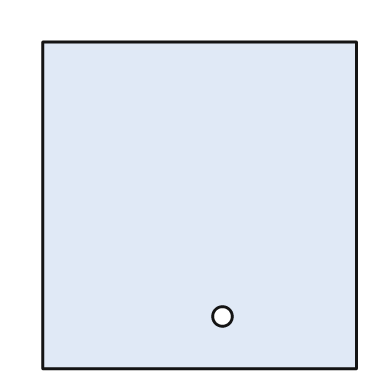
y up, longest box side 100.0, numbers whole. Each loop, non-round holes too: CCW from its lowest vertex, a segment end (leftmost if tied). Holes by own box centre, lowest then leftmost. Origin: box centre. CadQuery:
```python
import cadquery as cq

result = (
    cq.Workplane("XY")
    .moveTo(-48.0, -50.0)
    .lineTo(48.0, -50.0)
    .lineTo(48.0, 50.0)
    .lineTo(-48.0, 50.0)
    .close()
    .moveTo(7.0, -34.0)
    .circle(3.0)
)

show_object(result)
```